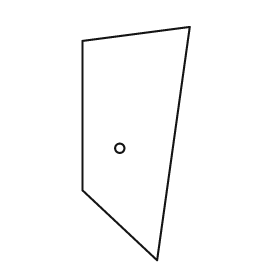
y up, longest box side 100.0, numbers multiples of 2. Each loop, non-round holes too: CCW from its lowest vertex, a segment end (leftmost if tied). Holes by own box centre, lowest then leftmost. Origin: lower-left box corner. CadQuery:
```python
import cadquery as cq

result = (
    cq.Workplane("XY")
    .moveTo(32.0, 0.0)
    .lineTo(46.0, 100.0)
    .lineTo(0.0, 94.0)
    .lineTo(0.0, 30.0)
    .close()
    .moveTo(16.0, 48.0)
    .circle(2.0)
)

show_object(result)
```